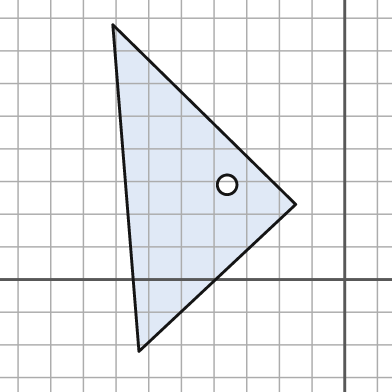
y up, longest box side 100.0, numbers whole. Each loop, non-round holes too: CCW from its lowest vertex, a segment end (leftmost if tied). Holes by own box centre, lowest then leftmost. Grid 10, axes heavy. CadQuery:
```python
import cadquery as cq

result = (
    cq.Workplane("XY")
    .moveTo(-63.0, -22.0)
    .lineTo(-15.0, 23.0)
    .lineTo(-71.0, 78.0)
    .close()
    .moveTo(-36.0, 29.0)
    .circle(3.0)
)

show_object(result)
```